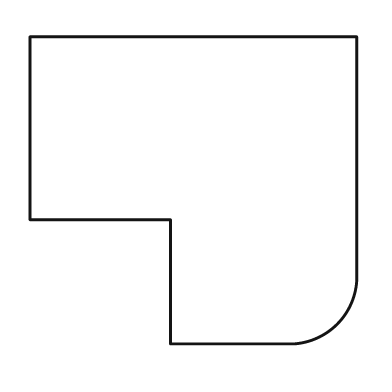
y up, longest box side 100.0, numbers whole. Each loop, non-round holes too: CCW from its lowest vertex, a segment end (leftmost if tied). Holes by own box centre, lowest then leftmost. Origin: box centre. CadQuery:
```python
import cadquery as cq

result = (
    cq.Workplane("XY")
    .moveTo(-7.0, -47.0)
    .lineTo(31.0, -47.0)
    .threePointArc((44.0, -41.0), (50.0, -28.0))
    .lineTo(50.0, 47.0)
    .lineTo(-50.0, 47.0)
    .lineTo(-50.0, -9.0)
    .lineTo(-7.0, -9.0)
    .close()
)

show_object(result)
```